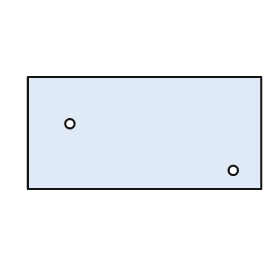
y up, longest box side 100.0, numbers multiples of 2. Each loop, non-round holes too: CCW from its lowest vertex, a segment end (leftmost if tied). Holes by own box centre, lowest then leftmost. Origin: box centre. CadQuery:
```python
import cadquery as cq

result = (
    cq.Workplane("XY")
    .moveTo(-50.0, -24.0)
    .lineTo(50.0, -24.0)
    .lineTo(50.0, 24.0)
    .lineTo(-50.0, 24.0)
    .close()
    .moveTo(38.0, -16.0)
    .circle(2.0)
    .moveTo(-32.0, 4.0)
    .circle(2.0)
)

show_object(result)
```